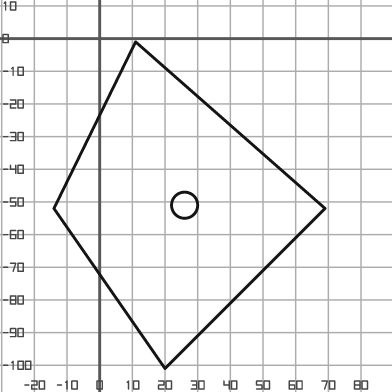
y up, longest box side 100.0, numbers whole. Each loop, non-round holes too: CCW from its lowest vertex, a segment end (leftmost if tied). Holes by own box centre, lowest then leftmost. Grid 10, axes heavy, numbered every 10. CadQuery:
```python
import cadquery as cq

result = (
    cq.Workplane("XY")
    .moveTo(20.0, -101.0)
    .lineTo(69.0, -52.0)
    .lineTo(11.0, -1.0)
    .lineTo(-14.0, -52.0)
    .close()
    .moveTo(26.0, -51.0)
    .circle(4.0)
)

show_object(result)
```